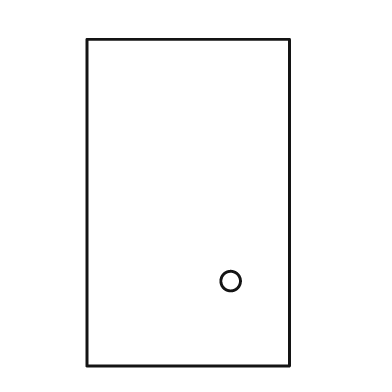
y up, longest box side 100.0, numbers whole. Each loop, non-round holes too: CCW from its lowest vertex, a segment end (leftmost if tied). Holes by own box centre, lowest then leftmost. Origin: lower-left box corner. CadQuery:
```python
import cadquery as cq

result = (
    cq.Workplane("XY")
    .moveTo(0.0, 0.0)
    .lineTo(62.0, 0.0)
    .lineTo(62.0, 100.0)
    .lineTo(0.0, 100.0)
    .close()
    .moveTo(44.0, 26.0)
    .circle(3.0)
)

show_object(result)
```